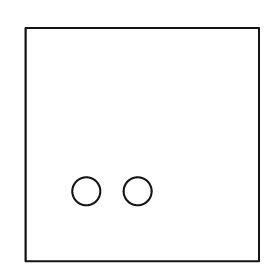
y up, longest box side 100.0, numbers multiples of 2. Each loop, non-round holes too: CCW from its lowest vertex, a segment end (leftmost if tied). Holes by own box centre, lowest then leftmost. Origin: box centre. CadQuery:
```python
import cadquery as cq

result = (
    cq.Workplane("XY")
    .moveTo(-50.0, -50.0)
    .lineTo(50.0, -50.0)
    .lineTo(50.0, 50.0)
    .lineTo(-50.0, 50.0)
    .close()
    .moveTo(-24.0, -20.0)
    .circle(6.0)
    .moveTo(-2.0, -20.0)
    .circle(6.0)
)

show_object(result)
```